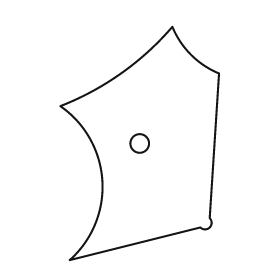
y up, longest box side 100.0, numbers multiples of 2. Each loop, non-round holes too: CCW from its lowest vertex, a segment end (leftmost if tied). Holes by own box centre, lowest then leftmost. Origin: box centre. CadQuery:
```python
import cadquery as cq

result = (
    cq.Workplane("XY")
    .moveTo(-30.0, -50.0)
    .lineTo(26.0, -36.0)
    .threePointArc((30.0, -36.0), (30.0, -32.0))
    .lineTo(34.0, 30.0)
    .threePointArc((22.0, 38.0), (14.0, 50.0))
    .threePointArc((-8.0, 30.0), (-34.0, 16.0))
    .threePointArc((-16.0, -16.0), (-30.0, -50.0))
    .close()
    .moveTo(0.0, 0.0)
    .circle(4.0)
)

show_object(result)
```